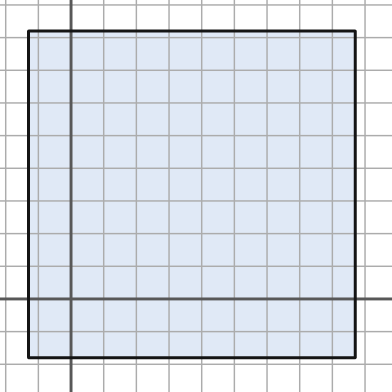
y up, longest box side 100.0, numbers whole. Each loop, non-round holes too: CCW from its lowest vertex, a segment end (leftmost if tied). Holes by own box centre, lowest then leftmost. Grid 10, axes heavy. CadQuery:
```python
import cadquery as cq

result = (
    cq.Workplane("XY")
    .moveTo(-13.0, -18.0)
    .lineTo(87.0, -18.0)
    .lineTo(87.0, 82.0)
    .lineTo(-13.0, 82.0)
    .close()
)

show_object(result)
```